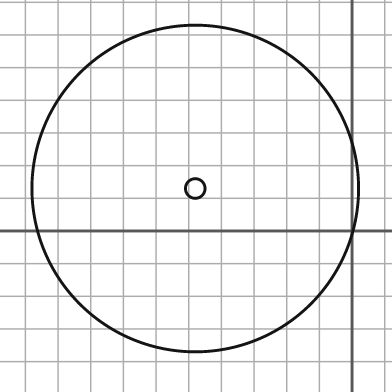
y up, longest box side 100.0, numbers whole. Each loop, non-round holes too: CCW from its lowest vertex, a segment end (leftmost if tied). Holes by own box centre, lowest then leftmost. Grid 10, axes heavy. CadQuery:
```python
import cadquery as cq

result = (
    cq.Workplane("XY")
    .moveTo(-48.0, 13.0)
    .circle(50.0)
    .moveTo(-48.0, 13.0)
    .circle(3.0)
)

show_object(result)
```